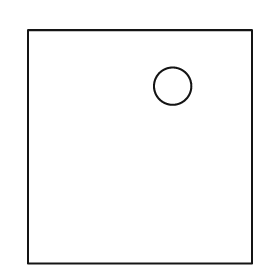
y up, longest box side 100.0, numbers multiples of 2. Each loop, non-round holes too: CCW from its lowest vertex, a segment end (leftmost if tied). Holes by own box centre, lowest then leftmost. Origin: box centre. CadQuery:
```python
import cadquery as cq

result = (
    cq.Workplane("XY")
    .moveTo(-48.0, -50.0)
    .lineTo(48.0, -50.0)
    .lineTo(48.0, 50.0)
    .lineTo(-48.0, 50.0)
    .close()
    .moveTo(14.0, 26.0)
    .circle(8.0)
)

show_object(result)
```